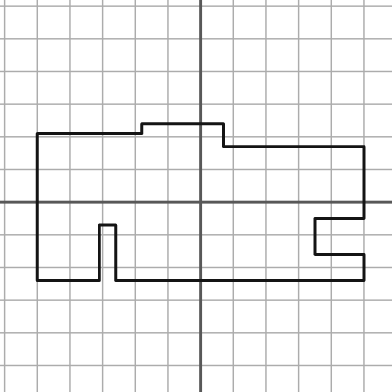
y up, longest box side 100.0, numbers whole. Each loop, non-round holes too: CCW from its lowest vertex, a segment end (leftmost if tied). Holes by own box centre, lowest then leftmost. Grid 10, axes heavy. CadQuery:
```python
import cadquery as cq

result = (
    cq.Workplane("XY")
    .moveTo(-50.0, -24.0)
    .lineTo(-31.0, -24.0)
    .lineTo(-31.0, -7.0)
    .lineTo(-26.0, -7.0)
    .lineTo(-26.0, -24.0)
    .lineTo(50.0, -24.0)
    .lineTo(50.0, -16.0)
    .lineTo(35.0, -16.0)
    .lineTo(35.0, -5.0)
    .lineTo(50.0, -5.0)
    .lineTo(50.0, 17.0)
    .lineTo(7.0, 17.0)
    .lineTo(7.0, 24.0)
    .lineTo(-18.0, 24.0)
    .lineTo(-18.0, 21.0)
    .lineTo(-50.0, 21.0)
    .close()
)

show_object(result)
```